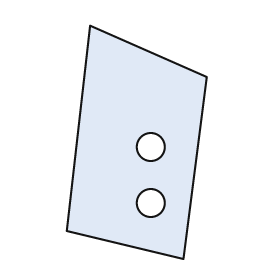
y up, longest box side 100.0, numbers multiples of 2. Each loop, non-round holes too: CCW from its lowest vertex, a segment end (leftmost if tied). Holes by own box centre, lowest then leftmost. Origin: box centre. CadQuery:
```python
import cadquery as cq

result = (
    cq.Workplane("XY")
    .moveTo(20.0, -50.0)
    .lineTo(30.0, 28.0)
    .lineTo(-20.0, 50.0)
    .lineTo(-30.0, -38.0)
    .close()
    .moveTo(6.0, -26.0)
    .circle(6.0)
    .moveTo(6.0, -2.0)
    .circle(6.0)
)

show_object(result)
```